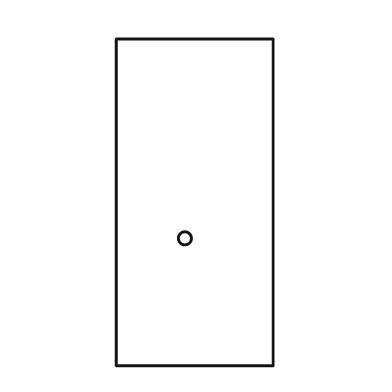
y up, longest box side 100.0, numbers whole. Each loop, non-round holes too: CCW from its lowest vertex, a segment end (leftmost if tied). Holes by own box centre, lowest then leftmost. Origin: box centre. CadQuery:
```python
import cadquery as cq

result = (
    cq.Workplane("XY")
    .moveTo(-24.0, -50.0)
    .lineTo(24.0, -50.0)
    .lineTo(24.0, 50.0)
    .lineTo(-24.0, 50.0)
    .close()
    .moveTo(-3.0, -11.0)
    .circle(2.0)
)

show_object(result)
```